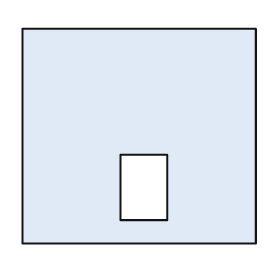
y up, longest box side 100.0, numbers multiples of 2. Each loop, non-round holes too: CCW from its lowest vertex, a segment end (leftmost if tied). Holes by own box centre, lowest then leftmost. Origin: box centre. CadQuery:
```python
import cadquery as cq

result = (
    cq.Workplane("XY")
    .moveTo(-50.0, -46.0)
    .lineTo(50.0, -46.0)
    .lineTo(50.0, 46.0)
    .lineTo(-50.0, 46.0)
    .close()
    .moveTo(-8.0, -36.0)
    .lineTo(12.0, -36.0)
    .lineTo(12.0, -8.0)
    .lineTo(-8.0, -8.0)
    .close()
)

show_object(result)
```